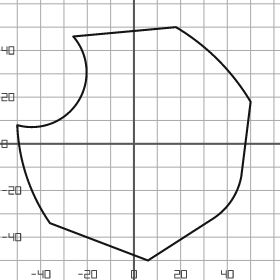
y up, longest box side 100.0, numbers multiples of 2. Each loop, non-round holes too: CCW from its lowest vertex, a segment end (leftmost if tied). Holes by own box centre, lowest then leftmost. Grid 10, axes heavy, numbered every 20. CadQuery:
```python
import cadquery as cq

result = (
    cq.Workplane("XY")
    .moveTo(6.0, -50.0)
    .lineTo(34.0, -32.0)
    .threePointArc((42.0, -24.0), (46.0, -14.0))
    .lineTo(50.0, 18.0)
    .threePointArc((36.0, 36.0), (18.0, 50.0))
    .lineTo(-26.0, 46.0)
    .threePointArc((-24.0, 18.0), (-50.0, 8.0))
    .threePointArc((-46.0, -14.0), (-36.0, -34.0))
    .close()
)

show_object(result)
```